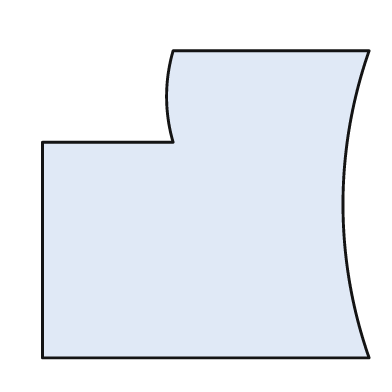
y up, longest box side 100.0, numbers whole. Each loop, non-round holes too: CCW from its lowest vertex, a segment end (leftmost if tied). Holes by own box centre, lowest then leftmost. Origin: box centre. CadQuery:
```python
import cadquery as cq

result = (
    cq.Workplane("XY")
    .moveTo(-50.0, -47.0)
    .lineTo(50.0, -47.0)
    .threePointArc((42.0, 0.0), (50.0, 47.0))
    .lineTo(-10.0, 47.0)
    .threePointArc((-12.0, 33.0), (-10.0, 19.0))
    .lineTo(-50.0, 19.0)
    .close()
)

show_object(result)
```